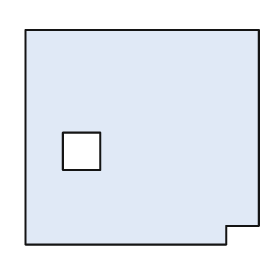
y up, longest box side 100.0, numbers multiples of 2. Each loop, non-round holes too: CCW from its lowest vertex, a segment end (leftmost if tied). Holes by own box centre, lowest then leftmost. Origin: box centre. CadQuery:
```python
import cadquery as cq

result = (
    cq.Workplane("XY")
    .moveTo(-50.0, -46.0)
    .lineTo(36.0, -46.0)
    .lineTo(36.0, -38.0)
    .lineTo(50.0, -38.0)
    .lineTo(50.0, 46.0)
    .lineTo(-50.0, 46.0)
    .close()
    .moveTo(-34.0, -14.0)
    .lineTo(-18.0, -14.0)
    .lineTo(-18.0, 2.0)
    .lineTo(-34.0, 2.0)
    .close()
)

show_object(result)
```